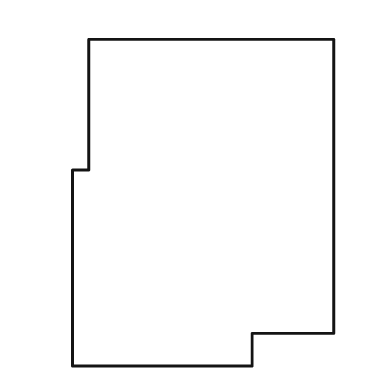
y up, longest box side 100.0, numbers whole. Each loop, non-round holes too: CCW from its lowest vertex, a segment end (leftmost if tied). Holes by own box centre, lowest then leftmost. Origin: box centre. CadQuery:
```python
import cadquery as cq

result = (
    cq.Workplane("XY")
    .moveTo(-40.0, -50.0)
    .lineTo(15.0, -50.0)
    .lineTo(15.0, -40.0)
    .lineTo(40.0, -40.0)
    .lineTo(40.0, 50.0)
    .lineTo(-35.0, 50.0)
    .lineTo(-35.0, 10.0)
    .lineTo(-40.0, 10.0)
    .close()
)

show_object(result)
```